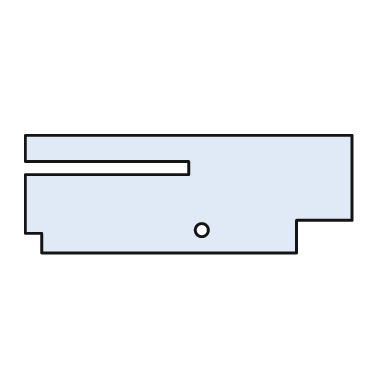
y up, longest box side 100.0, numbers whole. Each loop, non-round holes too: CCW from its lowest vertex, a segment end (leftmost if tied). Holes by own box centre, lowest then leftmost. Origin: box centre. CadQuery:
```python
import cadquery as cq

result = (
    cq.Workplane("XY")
    .moveTo(-45.0, -18.0)
    .lineTo(33.0, -18.0)
    .lineTo(33.0, -8.0)
    .lineTo(50.0, -8.0)
    .lineTo(50.0, 18.0)
    .lineTo(-50.0, 18.0)
    .lineTo(-50.0, 10.0)
    .lineTo(0.0, 10.0)
    .lineTo(0.0, 6.0)
    .lineTo(-50.0, 6.0)
    .lineTo(-50.0, -12.0)
    .lineTo(-45.0, -12.0)
    .close()
    .moveTo(4.0, -11.0)
    .circle(2.0)
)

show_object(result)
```